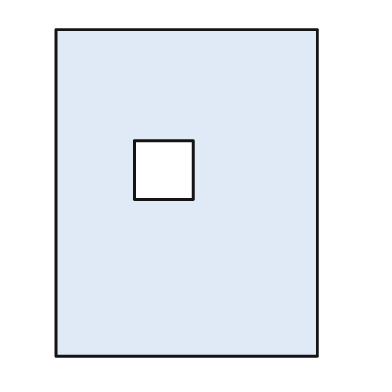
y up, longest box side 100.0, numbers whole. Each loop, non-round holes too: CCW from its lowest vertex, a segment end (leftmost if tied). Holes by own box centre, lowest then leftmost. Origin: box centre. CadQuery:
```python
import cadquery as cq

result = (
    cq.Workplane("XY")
    .moveTo(-40.0, -50.0)
    .lineTo(40.0, -50.0)
    .lineTo(40.0, 50.0)
    .lineTo(-40.0, 50.0)
    .close()
    .moveTo(-16.0, -2.0)
    .lineTo(2.0, -2.0)
    .lineTo(2.0, 16.0)
    .lineTo(-16.0, 16.0)
    .close()
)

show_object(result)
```